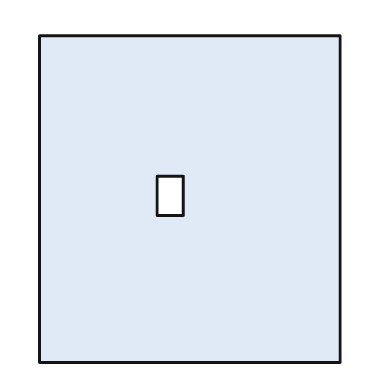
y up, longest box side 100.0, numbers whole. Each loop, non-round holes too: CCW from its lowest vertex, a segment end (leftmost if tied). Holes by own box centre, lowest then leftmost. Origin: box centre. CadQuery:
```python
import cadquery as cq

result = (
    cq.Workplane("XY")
    .moveTo(-46.0, -50.0)
    .lineTo(46.0, -50.0)
    .lineTo(46.0, 50.0)
    .lineTo(-46.0, 50.0)
    .close()
    .moveTo(-10.0, -5.0)
    .lineTo(-2.0, -5.0)
    .lineTo(-2.0, 7.0)
    .lineTo(-10.0, 7.0)
    .close()
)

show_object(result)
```